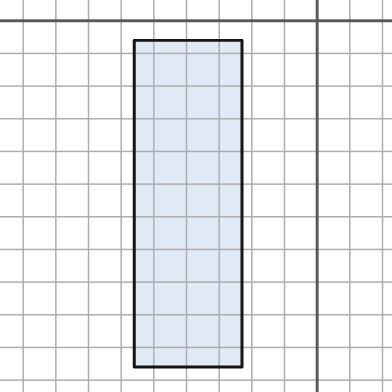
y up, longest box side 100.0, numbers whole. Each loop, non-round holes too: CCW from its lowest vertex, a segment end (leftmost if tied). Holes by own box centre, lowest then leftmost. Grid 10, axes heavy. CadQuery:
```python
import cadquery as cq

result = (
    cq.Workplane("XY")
    .moveTo(-56.0, -106.0)
    .lineTo(-23.0, -106.0)
    .lineTo(-23.0, -6.0)
    .lineTo(-56.0, -6.0)
    .close()
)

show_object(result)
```